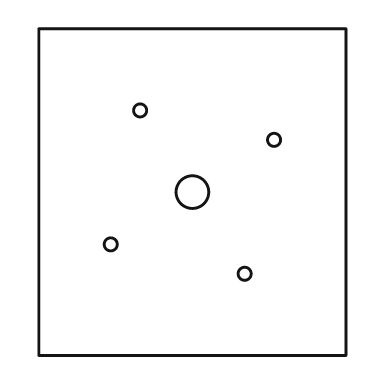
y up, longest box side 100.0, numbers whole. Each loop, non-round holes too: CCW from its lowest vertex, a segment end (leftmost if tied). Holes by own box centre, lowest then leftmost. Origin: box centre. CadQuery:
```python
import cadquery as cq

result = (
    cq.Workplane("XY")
    .moveTo(-47.0, -50.0)
    .lineTo(47.0, -50.0)
    .lineTo(47.0, 50.0)
    .lineTo(-47.0, 50.0)
    .close()
    .moveTo(16.0, -25.0)
    .circle(2.0)
    .moveTo(-25.0, -16.0)
    .circle(2.0)
    .moveTo(0.0, 0.0)
    .circle(5.0)
    .moveTo(25.0, 16.0)
    .circle(2.0)
    .moveTo(-16.0, 25.0)
    .circle(2.0)
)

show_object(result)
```